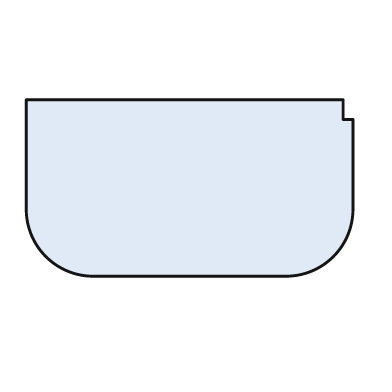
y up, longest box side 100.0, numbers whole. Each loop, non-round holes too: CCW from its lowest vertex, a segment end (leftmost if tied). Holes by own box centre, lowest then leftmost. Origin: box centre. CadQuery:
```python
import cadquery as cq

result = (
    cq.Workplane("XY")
    .moveTo(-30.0, -27.0)
    .lineTo(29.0, -27.0)
    .threePointArc((44.0, -21.0), (50.0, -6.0))
    .lineTo(50.0, 21.0)
    .lineTo(47.0, 21.0)
    .lineTo(47.0, 27.0)
    .lineTo(-50.0, 27.0)
    .lineTo(-50.0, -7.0)
    .threePointArc((-44.0, -21.0), (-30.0, -27.0))
    .close()
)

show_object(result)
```